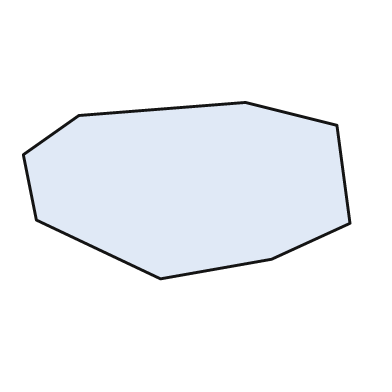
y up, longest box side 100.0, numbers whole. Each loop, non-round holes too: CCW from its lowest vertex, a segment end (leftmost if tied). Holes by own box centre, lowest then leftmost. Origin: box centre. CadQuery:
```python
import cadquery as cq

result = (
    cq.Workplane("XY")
    .moveTo(-8.0, -27.0)
    .lineTo(26.0, -21.0)
    .lineTo(50.0, -10.0)
    .lineTo(46.0, 20.0)
    .lineTo(18.0, 27.0)
    .lineTo(-33.0, 23.0)
    .lineTo(-50.0, 11.0)
    .lineTo(-46.0, -9.0)
    .close()
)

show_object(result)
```